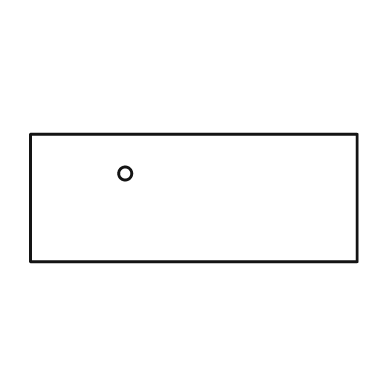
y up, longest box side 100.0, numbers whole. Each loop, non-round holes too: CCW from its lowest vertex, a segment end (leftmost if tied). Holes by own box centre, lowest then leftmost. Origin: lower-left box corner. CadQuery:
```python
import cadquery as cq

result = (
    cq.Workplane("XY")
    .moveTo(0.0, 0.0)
    .lineTo(100.0, 0.0)
    .lineTo(100.0, 39.0)
    .lineTo(0.0, 39.0)
    .close()
    .moveTo(29.0, 27.0)
    .circle(2.0)
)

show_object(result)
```